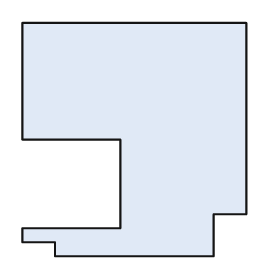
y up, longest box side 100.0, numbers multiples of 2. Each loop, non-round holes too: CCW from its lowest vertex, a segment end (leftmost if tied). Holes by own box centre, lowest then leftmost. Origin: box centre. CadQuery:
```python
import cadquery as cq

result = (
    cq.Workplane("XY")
    .moveTo(-34.0, -50.0)
    .lineTo(34.0, -50.0)
    .lineTo(34.0, -32.0)
    .lineTo(48.0, -32.0)
    .lineTo(48.0, 50.0)
    .lineTo(-48.0, 50.0)
    .lineTo(-48.0, 0.0)
    .lineTo(-6.0, 0.0)
    .lineTo(-6.0, -38.0)
    .lineTo(-48.0, -38.0)
    .lineTo(-48.0, -44.0)
    .lineTo(-34.0, -44.0)
    .close()
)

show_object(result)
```